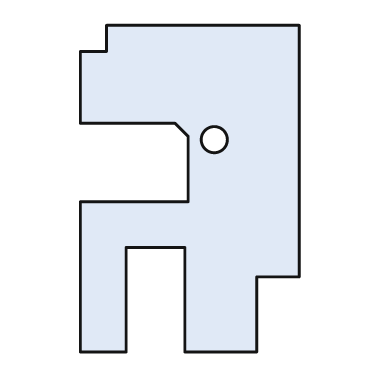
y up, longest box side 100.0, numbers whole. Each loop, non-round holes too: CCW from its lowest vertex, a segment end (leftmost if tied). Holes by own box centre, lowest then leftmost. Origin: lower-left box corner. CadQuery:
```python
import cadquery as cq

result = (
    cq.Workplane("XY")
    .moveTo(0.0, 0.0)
    .lineTo(14.0, 0.0)
    .lineTo(14.0, 32.0)
    .lineTo(32.0, 32.0)
    .lineTo(32.0, 0.0)
    .lineTo(54.0, 0.0)
    .lineTo(54.0, 23.0)
    .lineTo(67.0, 23.0)
    .lineTo(67.0, 100.0)
    .lineTo(8.0, 100.0)
    .lineTo(8.0, 92.0)
    .lineTo(0.0, 92.0)
    .lineTo(0.0, 70.0)
    .lineTo(29.0, 70.0)
    .lineTo(33.0, 66.0)
    .lineTo(33.0, 46.0)
    .lineTo(0.0, 46.0)
    .close()
    .moveTo(41.0, 65.0)
    .circle(4.0)
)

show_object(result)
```